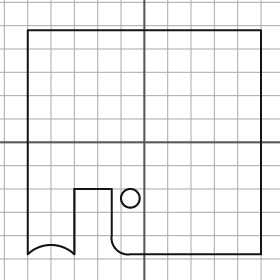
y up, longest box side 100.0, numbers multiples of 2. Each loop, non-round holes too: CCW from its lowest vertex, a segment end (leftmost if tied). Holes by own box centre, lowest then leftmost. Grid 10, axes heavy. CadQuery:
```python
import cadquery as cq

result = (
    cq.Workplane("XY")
    .moveTo(-50.0, -48.0)
    .threePointArc((-40.0, -44.0), (-30.0, -48.0))
    .lineTo(-30.0, -20.0)
    .lineTo(-14.0, -20.0)
    .lineTo(-14.0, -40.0)
    .threePointArc((-12.0, -46.0), (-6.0, -48.0))
    .lineTo(50.0, -48.0)
    .lineTo(50.0, 48.0)
    .lineTo(-50.0, 48.0)
    .close()
    .moveTo(-6.0, -24.0)
    .circle(4.0)
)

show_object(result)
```